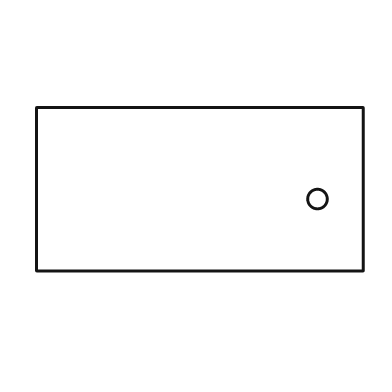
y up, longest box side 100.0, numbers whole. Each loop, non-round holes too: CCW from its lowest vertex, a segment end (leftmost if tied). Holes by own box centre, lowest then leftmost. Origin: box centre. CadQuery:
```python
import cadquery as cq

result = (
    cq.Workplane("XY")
    .moveTo(-50.0, -25.0)
    .lineTo(50.0, -25.0)
    .lineTo(50.0, 25.0)
    .lineTo(-50.0, 25.0)
    .close()
    .moveTo(36.0, -3.0)
    .circle(3.0)
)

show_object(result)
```